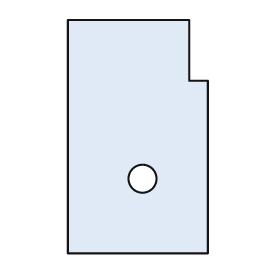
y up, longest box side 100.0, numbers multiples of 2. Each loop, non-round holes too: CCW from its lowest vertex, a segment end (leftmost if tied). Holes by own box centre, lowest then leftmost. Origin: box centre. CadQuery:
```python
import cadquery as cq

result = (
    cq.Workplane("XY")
    .moveTo(-30.0, -50.0)
    .lineTo(30.0, -50.0)
    .lineTo(30.0, 24.0)
    .lineTo(22.0, 24.0)
    .lineTo(22.0, 50.0)
    .lineTo(-30.0, 50.0)
    .close()
    .moveTo(2.0, -18.0)
    .circle(6.0)
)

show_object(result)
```